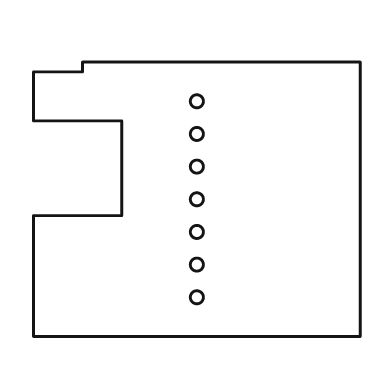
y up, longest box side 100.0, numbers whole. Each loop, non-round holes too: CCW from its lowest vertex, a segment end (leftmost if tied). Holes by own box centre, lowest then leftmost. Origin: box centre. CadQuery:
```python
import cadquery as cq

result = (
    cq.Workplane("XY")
    .moveTo(-50.0, -42.0)
    .lineTo(50.0, -42.0)
    .lineTo(50.0, 42.0)
    .lineTo(-35.0, 42.0)
    .lineTo(-35.0, 39.0)
    .lineTo(-50.0, 39.0)
    .lineTo(-50.0, 24.0)
    .lineTo(-23.0, 24.0)
    .lineTo(-23.0, -5.0)
    .lineTo(-50.0, -5.0)
    .close()
    .moveTo(0.0, -30.0)
    .circle(2.0)
    .moveTo(0.0, -20.0)
    .circle(2.0)
    .moveTo(0.0, -10.0)
    .circle(2.0)
    .moveTo(0.0, 0.0)
    .circle(2.0)
    .moveTo(0.0, 10.0)
    .circle(2.0)
    .moveTo(0.0, 20.0)
    .circle(2.0)
    .moveTo(0.0, 30.0)
    .circle(2.0)
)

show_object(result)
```